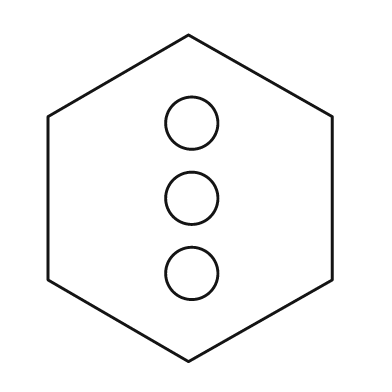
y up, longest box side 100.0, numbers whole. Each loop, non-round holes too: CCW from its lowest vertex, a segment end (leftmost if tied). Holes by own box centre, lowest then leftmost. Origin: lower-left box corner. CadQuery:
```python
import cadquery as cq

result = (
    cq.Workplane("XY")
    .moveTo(43.0, 0.0)
    .lineTo(87.0, 25.0)
    .lineTo(87.0, 75.0)
    .lineTo(43.0, 100.0)
    .lineTo(0.0, 75.0)
    .lineTo(0.0, 25.0)
    .close()
    .moveTo(44.0, 27.0)
    .circle(8.0)
    .moveTo(44.0, 50.0)
    .circle(8.0)
    .moveTo(44.0, 73.0)
    .circle(8.0)
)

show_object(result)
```